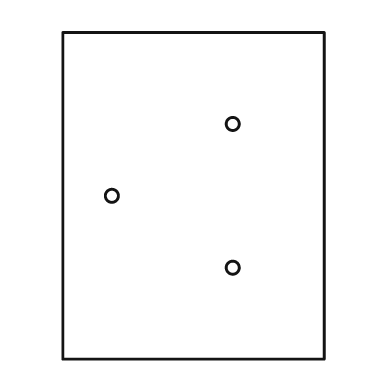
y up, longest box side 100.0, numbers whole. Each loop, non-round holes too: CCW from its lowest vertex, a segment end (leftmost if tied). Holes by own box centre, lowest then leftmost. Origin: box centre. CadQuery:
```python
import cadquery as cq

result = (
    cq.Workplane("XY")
    .moveTo(-40.0, -50.0)
    .lineTo(40.0, -50.0)
    .lineTo(40.0, 50.0)
    .lineTo(-40.0, 50.0)
    .close()
    .moveTo(12.0, -22.0)
    .circle(2.0)
    .moveTo(-25.0, 0.0)
    .circle(2.0)
    .moveTo(12.0, 22.0)
    .circle(2.0)
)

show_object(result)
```